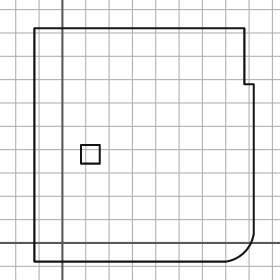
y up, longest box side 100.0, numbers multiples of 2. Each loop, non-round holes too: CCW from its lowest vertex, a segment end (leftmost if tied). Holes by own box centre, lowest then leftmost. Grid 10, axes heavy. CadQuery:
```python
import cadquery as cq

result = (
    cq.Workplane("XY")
    .moveTo(-12.0, -8.0)
    .lineTo(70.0, -8.0)
    .threePointArc((78.0, -4.0), (82.0, 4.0))
    .lineTo(82.0, 68.0)
    .lineTo(78.0, 68.0)
    .lineTo(78.0, 92.0)
    .lineTo(-12.0, 92.0)
    .close()
    .moveTo(8.0, 34.0)
    .lineTo(16.0, 34.0)
    .lineTo(16.0, 42.0)
    .lineTo(8.0, 42.0)
    .close()
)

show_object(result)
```